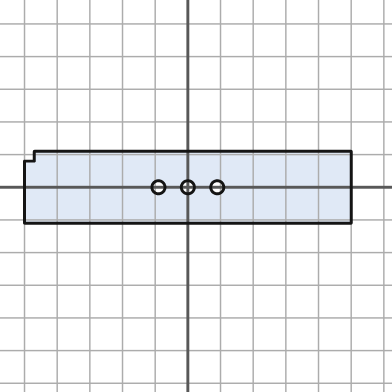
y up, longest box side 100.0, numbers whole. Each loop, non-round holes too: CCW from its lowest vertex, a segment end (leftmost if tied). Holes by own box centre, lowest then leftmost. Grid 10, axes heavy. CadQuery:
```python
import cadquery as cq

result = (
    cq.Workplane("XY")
    .moveTo(-50.0, -11.0)
    .lineTo(50.0, -11.0)
    .lineTo(50.0, 11.0)
    .lineTo(-47.0, 11.0)
    .lineTo(-47.0, 8.0)
    .lineTo(-50.0, 8.0)
    .close()
    .moveTo(-9.0, 0.0)
    .circle(2.0)
    .moveTo(0.0, 0.0)
    .circle(2.0)
    .moveTo(9.0, 0.0)
    .circle(2.0)
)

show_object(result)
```